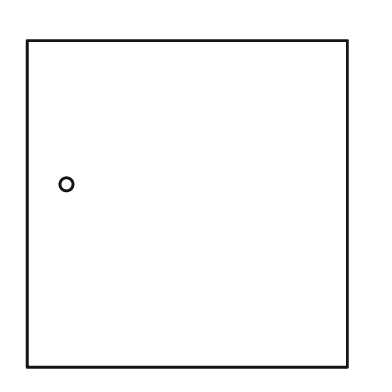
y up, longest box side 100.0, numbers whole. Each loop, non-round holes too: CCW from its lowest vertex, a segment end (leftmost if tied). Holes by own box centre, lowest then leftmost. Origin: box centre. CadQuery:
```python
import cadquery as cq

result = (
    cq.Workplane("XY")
    .moveTo(-49.0, -50.0)
    .lineTo(49.0, -50.0)
    .lineTo(49.0, 50.0)
    .lineTo(-49.0, 50.0)
    .close()
    .moveTo(-37.0, 6.0)
    .circle(2.0)
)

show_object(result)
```